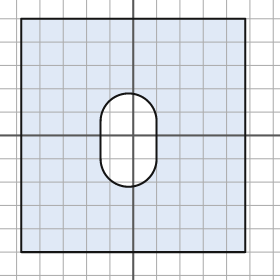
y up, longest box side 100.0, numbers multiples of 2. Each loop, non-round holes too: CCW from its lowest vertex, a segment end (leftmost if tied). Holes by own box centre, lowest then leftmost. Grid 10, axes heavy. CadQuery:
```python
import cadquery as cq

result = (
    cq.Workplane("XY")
    .moveTo(-48.0, -50.0)
    .lineTo(48.0, -50.0)
    .lineTo(48.0, 50.0)
    .lineTo(-48.0, 50.0)
    .close()
    .moveTo(-14.0, -10.0)
    .threePointArc((-2.0, -22.0), (10.0, -10.0))
    .lineTo(10.0, 6.0)
    .threePointArc((-2.0, 18.0), (-14.0, 6.0))
    .close()
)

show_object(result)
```